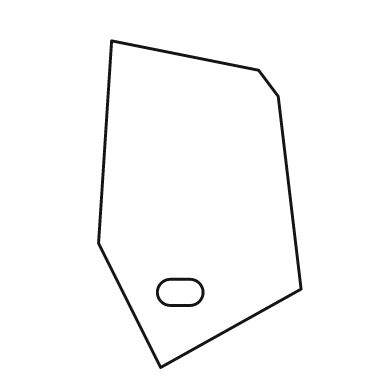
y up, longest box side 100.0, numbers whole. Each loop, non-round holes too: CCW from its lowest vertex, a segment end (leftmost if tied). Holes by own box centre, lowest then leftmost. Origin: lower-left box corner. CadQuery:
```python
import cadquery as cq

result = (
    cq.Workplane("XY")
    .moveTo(19.0, 0.0)
    .lineTo(62.0, 24.0)
    .lineTo(55.0, 83.0)
    .lineTo(49.0, 91.0)
    .lineTo(4.0, 100.0)
    .lineTo(0.0, 38.0)
    .close()
    .moveTo(22.0, 19.0)
    .lineTo(28.0, 19.0)
    .threePointArc((32.0, 23.0), (28.0, 27.0))
    .lineTo(22.0, 27.0)
    .threePointArc((18.0, 23.0), (22.0, 19.0))
    .close()
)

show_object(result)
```